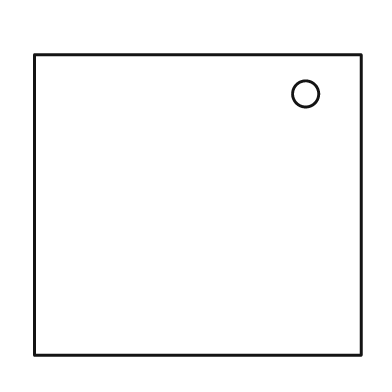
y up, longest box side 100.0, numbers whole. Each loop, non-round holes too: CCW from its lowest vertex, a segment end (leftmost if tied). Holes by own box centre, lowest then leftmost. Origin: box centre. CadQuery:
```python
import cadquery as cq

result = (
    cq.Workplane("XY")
    .moveTo(-50.0, -46.0)
    .lineTo(50.0, -46.0)
    .lineTo(50.0, 46.0)
    .lineTo(-50.0, 46.0)
    .close()
    .moveTo(33.0, 34.0)
    .circle(4.0)
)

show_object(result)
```